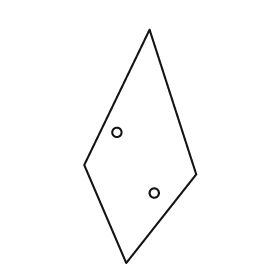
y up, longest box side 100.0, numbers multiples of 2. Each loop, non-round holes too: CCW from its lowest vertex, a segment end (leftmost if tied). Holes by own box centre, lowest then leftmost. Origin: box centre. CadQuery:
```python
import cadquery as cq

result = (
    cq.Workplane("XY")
    .moveTo(-6.0, -50.0)
    .lineTo(24.0, -12.0)
    .lineTo(4.0, 50.0)
    .lineTo(-24.0, -8.0)
    .close()
    .moveTo(6.0, -20.0)
    .circle(2.0)
    .moveTo(-10.0, 6.0)
    .circle(2.0)
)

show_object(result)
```